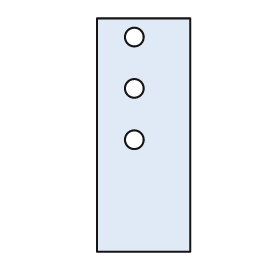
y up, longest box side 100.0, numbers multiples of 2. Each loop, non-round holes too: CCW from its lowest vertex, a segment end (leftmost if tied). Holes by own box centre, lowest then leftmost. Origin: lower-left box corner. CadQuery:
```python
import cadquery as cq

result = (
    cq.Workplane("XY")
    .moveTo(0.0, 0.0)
    .lineTo(40.0, 0.0)
    .lineTo(40.0, 100.0)
    .lineTo(0.0, 100.0)
    .close()
    .moveTo(16.0, 48.0)
    .circle(4.0)
    .moveTo(16.0, 70.0)
    .circle(4.0)
    .moveTo(16.0, 92.0)
    .circle(4.0)
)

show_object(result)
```